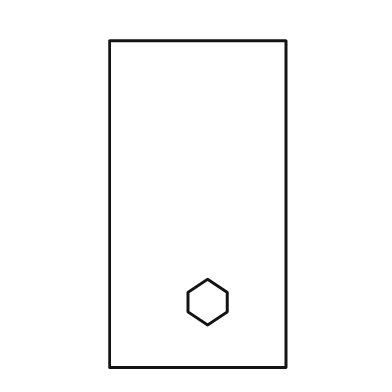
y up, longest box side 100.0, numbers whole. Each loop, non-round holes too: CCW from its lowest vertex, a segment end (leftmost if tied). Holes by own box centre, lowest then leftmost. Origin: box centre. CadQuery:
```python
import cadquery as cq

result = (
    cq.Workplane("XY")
    .moveTo(-27.0, -50.0)
    .lineTo(27.0, -50.0)
    .lineTo(27.0, 50.0)
    .lineTo(-27.0, 50.0)
    .close()
    .moveTo(3.0, -37.0)
    .lineTo(9.0, -33.0)
    .lineTo(9.0, -27.0)
    .lineTo(3.0, -23.0)
    .lineTo(-3.0, -27.0)
    .lineTo(-3.0, -33.0)
    .close()
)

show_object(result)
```